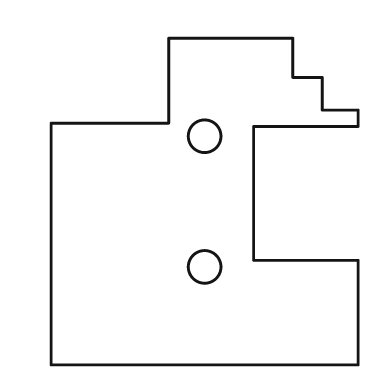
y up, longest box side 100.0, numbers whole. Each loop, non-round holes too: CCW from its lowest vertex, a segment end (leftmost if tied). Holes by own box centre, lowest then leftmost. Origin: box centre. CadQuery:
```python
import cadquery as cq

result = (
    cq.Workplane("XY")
    .moveTo(-47.0, -50.0)
    .lineTo(47.0, -50.0)
    .lineTo(47.0, -18.0)
    .lineTo(15.0, -18.0)
    .lineTo(15.0, 23.0)
    .lineTo(47.0, 23.0)
    .lineTo(47.0, 28.0)
    .lineTo(36.0, 28.0)
    .lineTo(36.0, 38.0)
    .lineTo(27.0, 38.0)
    .lineTo(27.0, 50.0)
    .lineTo(-11.0, 50.0)
    .lineTo(-11.0, 24.0)
    .lineTo(-47.0, 24.0)
    .close()
    .moveTo(0.0, -20.0)
    .circle(5.0)
    .moveTo(0.0, 20.0)
    .circle(5.0)
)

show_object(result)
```